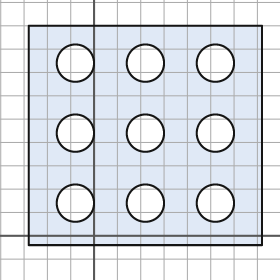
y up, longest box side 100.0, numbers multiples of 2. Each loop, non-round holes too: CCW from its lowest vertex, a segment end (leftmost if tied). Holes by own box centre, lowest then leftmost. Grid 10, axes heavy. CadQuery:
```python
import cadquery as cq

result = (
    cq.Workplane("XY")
    .moveTo(-28.0, -4.0)
    .lineTo(72.0, -4.0)
    .lineTo(72.0, 90.0)
    .lineTo(-28.0, 90.0)
    .close()
    .moveTo(-8.0, 14.0)
    .circle(8.0)
    .moveTo(22.0, 14.0)
    .circle(8.0)
    .moveTo(52.0, 14.0)
    .circle(8.0)
    .moveTo(-8.0, 44.0)
    .circle(8.0)
    .moveTo(22.0, 44.0)
    .circle(8.0)
    .moveTo(52.0, 44.0)
    .circle(8.0)
    .moveTo(-8.0, 74.0)
    .circle(8.0)
    .moveTo(22.0, 74.0)
    .circle(8.0)
    .moveTo(52.0, 74.0)
    .circle(8.0)
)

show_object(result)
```